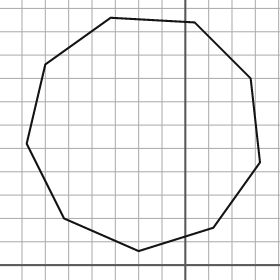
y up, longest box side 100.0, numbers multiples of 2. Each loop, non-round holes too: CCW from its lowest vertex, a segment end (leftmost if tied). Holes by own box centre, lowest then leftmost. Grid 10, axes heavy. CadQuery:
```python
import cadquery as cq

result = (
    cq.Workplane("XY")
    .moveTo(-20.0, 6.0)
    .lineTo(12.0, 16.0)
    .lineTo(32.0, 44.0)
    .lineTo(28.0, 80.0)
    .lineTo(4.0, 104.0)
    .lineTo(-32.0, 106.0)
    .lineTo(-60.0, 86.0)
    .lineTo(-68.0, 52.0)
    .lineTo(-52.0, 20.0)
    .close()
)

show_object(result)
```